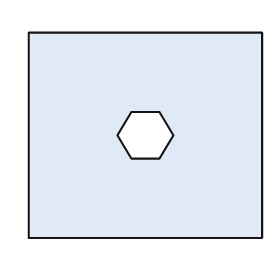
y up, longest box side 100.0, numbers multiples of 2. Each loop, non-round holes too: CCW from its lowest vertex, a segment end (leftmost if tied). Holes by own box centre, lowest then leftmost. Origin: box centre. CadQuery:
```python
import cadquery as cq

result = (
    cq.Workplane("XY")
    .moveTo(-50.0, -44.0)
    .lineTo(50.0, -44.0)
    .lineTo(50.0, 44.0)
    .lineTo(-50.0, 44.0)
    .close()
    .moveTo(-6.0, -10.0)
    .lineTo(6.0, -10.0)
    .lineTo(12.0, 0.0)
    .lineTo(6.0, 10.0)
    .lineTo(-6.0, 10.0)
    .lineTo(-12.0, 0.0)
    .close()
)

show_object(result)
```